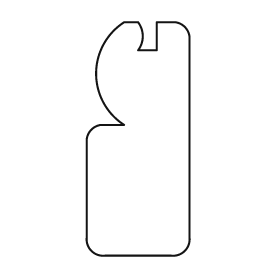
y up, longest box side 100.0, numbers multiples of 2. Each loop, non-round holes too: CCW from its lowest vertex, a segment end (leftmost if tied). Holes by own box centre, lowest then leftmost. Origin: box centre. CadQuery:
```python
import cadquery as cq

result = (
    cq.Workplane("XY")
    .moveTo(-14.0, -50.0)
    .lineTo(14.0, -50.0)
    .threePointArc((20.0, -48.0), (22.0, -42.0))
    .lineTo(22.0, 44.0)
    .threePointArc((20.0, 48.0), (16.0, 50.0))
    .lineTo(8.0, 50.0)
    .lineTo(8.0, 38.0)
    .lineTo(0.0, 38.0)
    .threePointArc((2.0, 44.0), (0.0, 50.0))
    .lineTo(-6.0, 50.0)
    .threePointArc((-18.0, 28.0), (-6.0, 6.0))
    .lineTo(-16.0, 6.0)
    .threePointArc((-20.0, 4.0), (-22.0, 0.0))
    .lineTo(-22.0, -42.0)
    .threePointArc((-20.0, -48.0), (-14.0, -50.0))
    .close()
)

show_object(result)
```